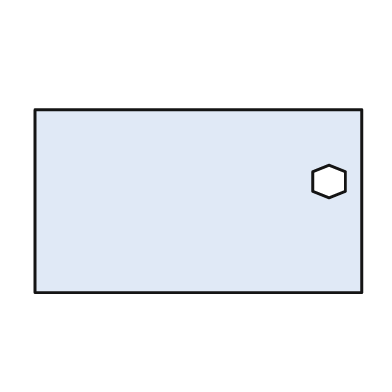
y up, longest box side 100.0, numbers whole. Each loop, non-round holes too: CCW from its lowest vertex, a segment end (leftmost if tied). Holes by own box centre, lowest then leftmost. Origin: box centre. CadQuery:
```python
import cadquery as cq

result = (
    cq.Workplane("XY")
    .moveTo(-50.0, -28.0)
    .lineTo(50.0, -28.0)
    .lineTo(50.0, 28.0)
    .lineTo(-50.0, 28.0)
    .close()
    .moveTo(40.0, 1.0)
    .lineTo(45.0, 3.0)
    .lineTo(45.0, 9.0)
    .lineTo(40.0, 11.0)
    .lineTo(35.0, 9.0)
    .lineTo(35.0, 3.0)
    .close()
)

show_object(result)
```